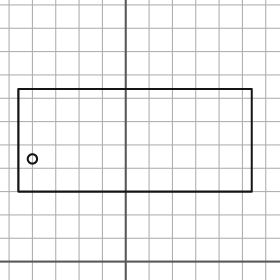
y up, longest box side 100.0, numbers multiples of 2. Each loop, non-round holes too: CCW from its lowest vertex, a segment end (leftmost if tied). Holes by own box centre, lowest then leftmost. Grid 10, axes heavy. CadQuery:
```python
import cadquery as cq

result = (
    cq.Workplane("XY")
    .moveTo(-46.0, 30.0)
    .lineTo(54.0, 30.0)
    .lineTo(54.0, 74.0)
    .lineTo(-46.0, 74.0)
    .close()
    .moveTo(-40.0, 44.0)
    .circle(2.0)
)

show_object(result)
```